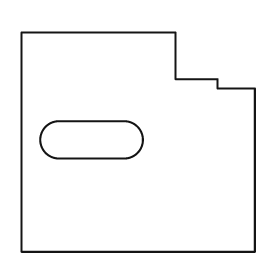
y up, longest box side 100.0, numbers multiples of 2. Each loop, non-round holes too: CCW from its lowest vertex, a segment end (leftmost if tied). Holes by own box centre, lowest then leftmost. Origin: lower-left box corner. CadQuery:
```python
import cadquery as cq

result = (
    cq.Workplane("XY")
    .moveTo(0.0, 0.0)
    .lineTo(100.0, 0.0)
    .lineTo(100.0, 70.0)
    .lineTo(84.0, 70.0)
    .lineTo(84.0, 74.0)
    .lineTo(66.0, 74.0)
    .lineTo(66.0, 94.0)
    .lineTo(0.0, 94.0)
    .close()
    .moveTo(16.0, 40.0)
    .lineTo(44.0, 40.0)
    .threePointArc((52.0, 48.0), (44.0, 56.0))
    .lineTo(16.0, 56.0)
    .threePointArc((8.0, 48.0), (16.0, 40.0))
    .close()
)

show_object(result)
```